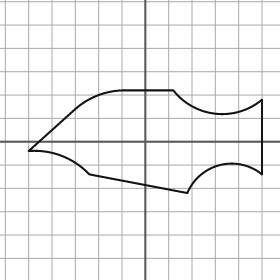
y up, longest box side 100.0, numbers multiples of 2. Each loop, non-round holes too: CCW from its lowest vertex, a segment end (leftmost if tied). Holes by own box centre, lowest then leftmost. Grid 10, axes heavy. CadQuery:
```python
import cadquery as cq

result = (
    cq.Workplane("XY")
    .moveTo(18.0, -22.0)
    .threePointArc((32.0, -10.0), (50.0, -14.0))
    .lineTo(50.0, 18.0)
    .threePointArc((30.0, 12.0), (12.0, 22.0))
    .lineTo(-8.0, 22.0)
    .threePointArc((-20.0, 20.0), (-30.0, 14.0))
    .lineTo(-50.0, -4.0)
    .threePointArc((-36.0, -6.0), (-24.0, -14.0))
    .close()
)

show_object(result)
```